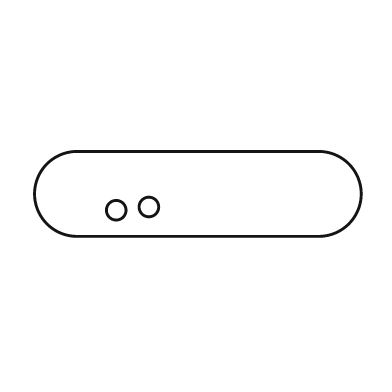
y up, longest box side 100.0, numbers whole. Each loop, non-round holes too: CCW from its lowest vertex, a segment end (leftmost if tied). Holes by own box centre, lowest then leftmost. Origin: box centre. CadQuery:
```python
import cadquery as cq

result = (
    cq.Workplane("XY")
    .moveTo(-37.0, -13.0)
    .lineTo(37.0, -13.0)
    .threePointArc((50.0, 0.0), (37.0, 13.0))
    .lineTo(-37.0, 13.0)
    .threePointArc((-50.0, 0.0), (-37.0, -13.0))
    .close()
    .moveTo(-25.0, -5.0)
    .circle(3.0)
    .moveTo(-15.0, -4.0)
    .circle(3.0)
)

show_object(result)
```